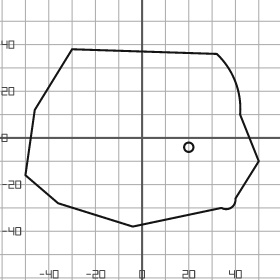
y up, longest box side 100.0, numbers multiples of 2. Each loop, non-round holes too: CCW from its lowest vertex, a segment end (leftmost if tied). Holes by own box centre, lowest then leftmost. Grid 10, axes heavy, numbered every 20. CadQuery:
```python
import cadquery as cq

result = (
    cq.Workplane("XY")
    .moveTo(-4.0, -38.0)
    .lineTo(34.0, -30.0)
    .threePointArc((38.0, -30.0), (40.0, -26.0))
    .lineTo(50.0, -10.0)
    .lineTo(42.0, 10.0)
    .threePointArc((40.0, 24.0), (32.0, 36.0))
    .lineTo(-30.0, 38.0)
    .lineTo(-46.0, 12.0)
    .lineTo(-50.0, -16.0)
    .lineTo(-36.0, -28.0)
    .close()
    .moveTo(20.0, -4.0)
    .circle(2.0)
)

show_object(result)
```